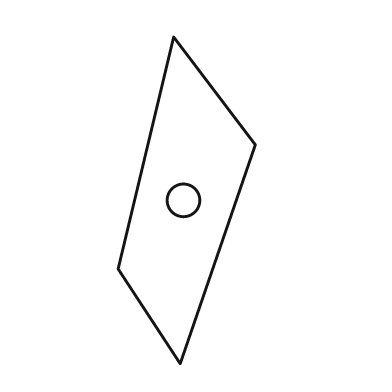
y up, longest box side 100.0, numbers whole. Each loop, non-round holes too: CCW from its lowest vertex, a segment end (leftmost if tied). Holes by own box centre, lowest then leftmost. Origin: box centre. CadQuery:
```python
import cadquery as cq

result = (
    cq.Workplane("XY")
    .moveTo(-2.0, -50.0)
    .lineTo(21.0, 17.0)
    .lineTo(-4.0, 50.0)
    .lineTo(-21.0, -21.0)
    .close()
    .moveTo(-1.0, 0.0)
    .circle(5.0)
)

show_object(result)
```